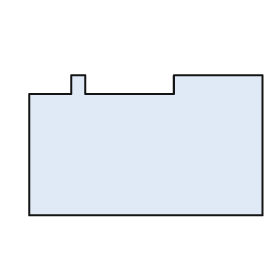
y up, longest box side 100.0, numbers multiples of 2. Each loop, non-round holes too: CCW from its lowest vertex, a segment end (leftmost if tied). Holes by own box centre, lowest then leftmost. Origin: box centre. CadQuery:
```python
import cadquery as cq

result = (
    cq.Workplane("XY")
    .moveTo(-50.0, -30.0)
    .lineTo(50.0, -30.0)
    .lineTo(50.0, 30.0)
    .lineTo(12.0, 30.0)
    .lineTo(12.0, 22.0)
    .lineTo(-26.0, 22.0)
    .lineTo(-26.0, 30.0)
    .lineTo(-32.0, 30.0)
    .lineTo(-32.0, 22.0)
    .lineTo(-50.0, 22.0)
    .close()
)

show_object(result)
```